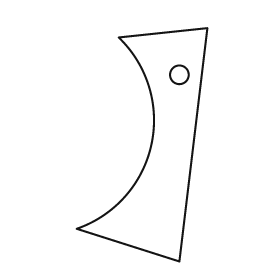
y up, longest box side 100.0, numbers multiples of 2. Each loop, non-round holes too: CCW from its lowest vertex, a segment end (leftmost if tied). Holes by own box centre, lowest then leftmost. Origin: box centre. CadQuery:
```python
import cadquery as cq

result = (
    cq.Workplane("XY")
    .moveTo(16.0, -50.0)
    .lineTo(28.0, 50.0)
    .lineTo(-10.0, 46.0)
    .threePointArc((4.0, 0.0), (-28.0, -36.0))
    .close()
    .moveTo(16.0, 30.0)
    .circle(4.0)
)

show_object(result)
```